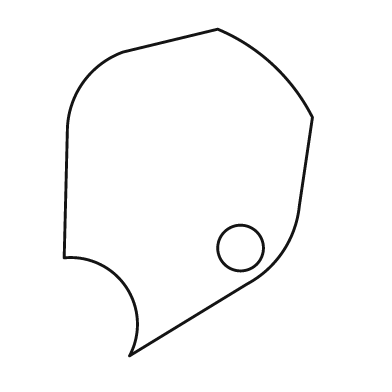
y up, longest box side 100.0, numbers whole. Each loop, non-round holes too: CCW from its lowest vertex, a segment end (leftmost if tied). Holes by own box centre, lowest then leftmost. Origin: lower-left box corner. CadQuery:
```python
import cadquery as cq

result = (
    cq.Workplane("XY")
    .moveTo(20.0, 0.0)
    .lineTo(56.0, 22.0)
    .threePointArc((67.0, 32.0), (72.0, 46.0))
    .lineTo(76.0, 73.0)
    .threePointArc((64.0, 89.0), (47.0, 100.0))
    .lineTo(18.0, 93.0)
    .threePointArc((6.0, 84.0), (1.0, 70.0))
    .lineTo(0.0, 30.0)
    .threePointArc((19.0, 21.0), (20.0, 0.0))
    .close()
    .moveTo(54.0, 33.0)
    .circle(7.0)
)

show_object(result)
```